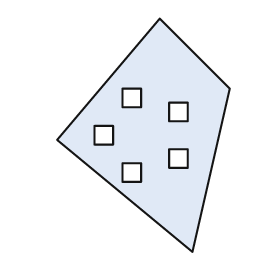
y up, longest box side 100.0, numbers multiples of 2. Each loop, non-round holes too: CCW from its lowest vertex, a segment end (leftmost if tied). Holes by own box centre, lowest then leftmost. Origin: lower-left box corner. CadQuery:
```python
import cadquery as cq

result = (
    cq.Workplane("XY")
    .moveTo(58.0, 0.0)
    .lineTo(74.0, 70.0)
    .lineTo(44.0, 100.0)
    .lineTo(0.0, 48.0)
    .close()
    .moveTo(28.0, 30.0)
    .lineTo(36.0, 30.0)
    .lineTo(36.0, 38.0)
    .lineTo(28.0, 38.0)
    .close()
    .moveTo(48.0, 36.0)
    .lineTo(56.0, 36.0)
    .lineTo(56.0, 44.0)
    .lineTo(48.0, 44.0)
    .close()
    .moveTo(16.0, 46.0)
    .lineTo(24.0, 46.0)
    .lineTo(24.0, 54.0)
    .lineTo(16.0, 54.0)
    .close()
    .moveTo(48.0, 56.0)
    .lineTo(56.0, 56.0)
    .lineTo(56.0, 64.0)
    .lineTo(48.0, 64.0)
    .close()
    .moveTo(28.0, 62.0)
    .lineTo(36.0, 62.0)
    .lineTo(36.0, 70.0)
    .lineTo(28.0, 70.0)
    .close()
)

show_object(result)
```